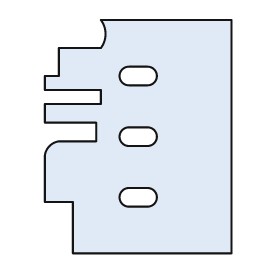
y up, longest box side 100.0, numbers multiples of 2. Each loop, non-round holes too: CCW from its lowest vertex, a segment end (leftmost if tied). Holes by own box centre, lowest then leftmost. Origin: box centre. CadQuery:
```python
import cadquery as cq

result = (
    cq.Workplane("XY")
    .moveTo(-28.0, -50.0)
    .lineTo(40.0, -50.0)
    .lineTo(40.0, 50.0)
    .lineTo(-16.0, 50.0)
    .threePointArc((-14.0, 44.0), (-16.0, 38.0))
    .lineTo(-34.0, 38.0)
    .lineTo(-34.0, 26.0)
    .lineTo(-40.0, 26.0)
    .lineTo(-40.0, 20.0)
    .lineTo(-16.0, 20.0)
    .lineTo(-16.0, 14.0)
    .lineTo(-40.0, 14.0)
    .lineTo(-40.0, 6.0)
    .lineTo(-18.0, 6.0)
    .lineTo(-18.0, -2.0)
    .lineTo(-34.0, -2.0)
    .threePointArc((-38.0, -4.0), (-40.0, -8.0))
    .lineTo(-40.0, -28.0)
    .lineTo(-28.0, -28.0)
    .close()
    .moveTo(-4.0, -30.0)
    .lineTo(4.0, -30.0)
    .threePointArc((8.0, -26.0), (4.0, -22.0))
    .lineTo(-4.0, -22.0)
    .threePointArc((-8.0, -26.0), (-4.0, -30.0))
    .close()
    .moveTo(-4.0, -4.0)
    .lineTo(4.0, -4.0)
    .threePointArc((8.0, 0.0), (4.0, 4.0))
    .lineTo(-4.0, 4.0)
    .threePointArc((-8.0, 0.0), (-4.0, -4.0))
    .close()
    .moveTo(-4.0, 22.0)
    .lineTo(4.0, 22.0)
    .threePointArc((8.0, 26.0), (4.0, 30.0))
    .lineTo(-4.0, 30.0)
    .threePointArc((-8.0, 26.0), (-4.0, 22.0))
    .close()
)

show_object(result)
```